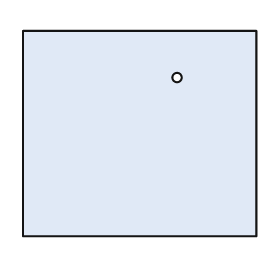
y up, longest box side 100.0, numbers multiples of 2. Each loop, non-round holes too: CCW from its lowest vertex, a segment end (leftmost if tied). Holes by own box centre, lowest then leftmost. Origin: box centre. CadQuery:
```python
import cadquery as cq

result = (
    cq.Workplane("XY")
    .moveTo(-50.0, -44.0)
    .lineTo(50.0, -44.0)
    .lineTo(50.0, 44.0)
    .lineTo(-50.0, 44.0)
    .close()
    .moveTo(16.0, 24.0)
    .circle(2.0)
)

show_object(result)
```